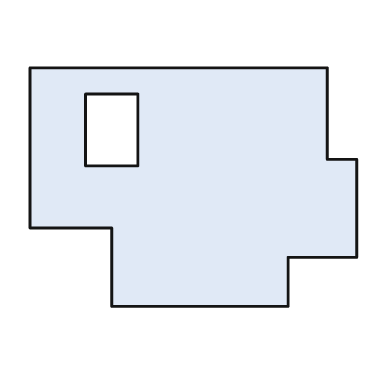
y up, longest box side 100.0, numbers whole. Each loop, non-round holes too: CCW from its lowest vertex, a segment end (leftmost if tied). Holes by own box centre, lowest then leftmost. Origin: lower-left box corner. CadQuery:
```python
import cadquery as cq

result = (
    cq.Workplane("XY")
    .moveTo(25.0, 0.0)
    .lineTo(79.0, 0.0)
    .lineTo(79.0, 15.0)
    .lineTo(100.0, 15.0)
    .lineTo(100.0, 45.0)
    .lineTo(91.0, 45.0)
    .lineTo(91.0, 73.0)
    .lineTo(0.0, 73.0)
    .lineTo(0.0, 24.0)
    .lineTo(25.0, 24.0)
    .close()
    .moveTo(17.0, 43.0)
    .lineTo(33.0, 43.0)
    .lineTo(33.0, 65.0)
    .lineTo(17.0, 65.0)
    .close()
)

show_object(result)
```